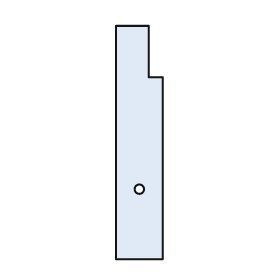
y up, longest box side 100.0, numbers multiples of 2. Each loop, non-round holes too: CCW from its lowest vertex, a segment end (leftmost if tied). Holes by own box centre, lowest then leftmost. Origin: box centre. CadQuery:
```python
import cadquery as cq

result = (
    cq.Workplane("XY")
    .moveTo(-10.0, -50.0)
    .lineTo(10.0, -50.0)
    .lineTo(10.0, 28.0)
    .lineTo(4.0, 28.0)
    .lineTo(4.0, 50.0)
    .lineTo(-10.0, 50.0)
    .close()
    .moveTo(0.0, -20.0)
    .circle(2.0)
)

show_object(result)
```